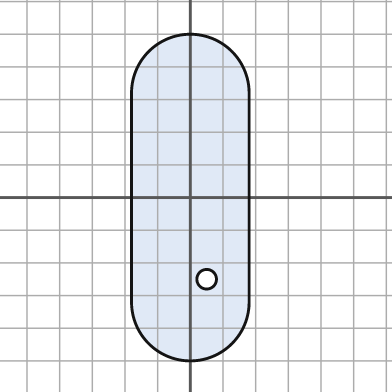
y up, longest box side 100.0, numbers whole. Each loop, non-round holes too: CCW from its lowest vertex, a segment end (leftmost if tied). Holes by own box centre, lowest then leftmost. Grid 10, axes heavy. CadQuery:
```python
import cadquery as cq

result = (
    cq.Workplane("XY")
    .moveTo(-18.0, -32.0)
    .threePointArc((0.0, -50.0), (18.0, -32.0))
    .lineTo(18.0, 32.0)
    .threePointArc((0.0, 50.0), (-18.0, 32.0))
    .close()
    .moveTo(5.0, -25.0)
    .circle(3.0)
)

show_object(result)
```